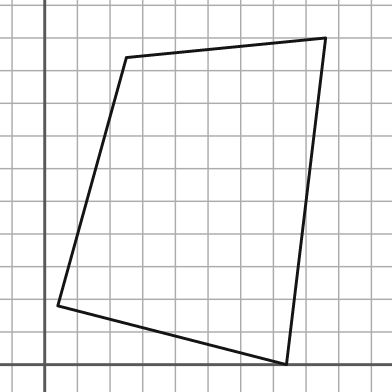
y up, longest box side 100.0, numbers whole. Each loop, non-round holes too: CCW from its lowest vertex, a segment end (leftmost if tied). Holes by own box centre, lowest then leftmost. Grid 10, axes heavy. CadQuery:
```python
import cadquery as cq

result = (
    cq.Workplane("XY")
    .moveTo(74.0, 0.0)
    .lineTo(86.0, 100.0)
    .lineTo(25.0, 94.0)
    .lineTo(4.0, 18.0)
    .close()
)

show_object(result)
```